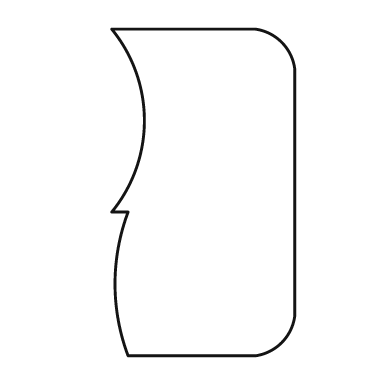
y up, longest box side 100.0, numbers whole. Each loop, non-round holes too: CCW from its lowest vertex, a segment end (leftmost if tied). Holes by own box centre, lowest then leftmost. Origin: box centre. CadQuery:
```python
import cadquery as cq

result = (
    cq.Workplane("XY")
    .moveTo(-23.0, -50.0)
    .lineTo(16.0, -50.0)
    .threePointArc((24.0, -46.0), (28.0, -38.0))
    .lineTo(28.0, 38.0)
    .threePointArc((24.0, 46.0), (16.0, 50.0))
    .lineTo(-28.0, 50.0)
    .threePointArc((-18.0, 22.0), (-28.0, -6.0))
    .lineTo(-23.0, -6.0)
    .threePointArc((-27.0, -28.0), (-23.0, -50.0))
    .close()
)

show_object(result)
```